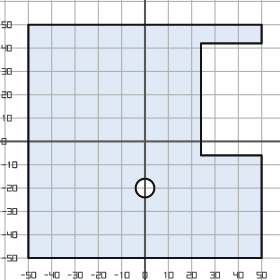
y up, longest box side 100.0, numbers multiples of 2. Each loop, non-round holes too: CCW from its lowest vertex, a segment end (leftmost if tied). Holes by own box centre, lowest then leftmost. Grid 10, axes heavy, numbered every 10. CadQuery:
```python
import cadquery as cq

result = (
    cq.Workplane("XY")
    .moveTo(-50.0, -50.0)
    .lineTo(50.0, -50.0)
    .lineTo(50.0, -6.0)
    .lineTo(24.0, -6.0)
    .lineTo(24.0, 42.0)
    .lineTo(50.0, 42.0)
    .lineTo(50.0, 50.0)
    .lineTo(-50.0, 50.0)
    .close()
    .moveTo(0.0, -20.0)
    .circle(4.0)
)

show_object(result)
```